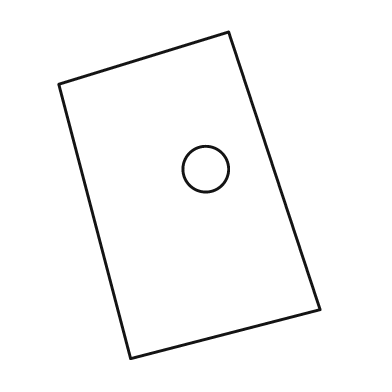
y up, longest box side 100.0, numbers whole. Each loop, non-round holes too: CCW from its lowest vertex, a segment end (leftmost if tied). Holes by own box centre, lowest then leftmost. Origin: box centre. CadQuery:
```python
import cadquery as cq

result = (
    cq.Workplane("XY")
    .moveTo(-18.0, -50.0)
    .lineTo(40.0, -35.0)
    .lineTo(12.0, 50.0)
    .lineTo(-40.0, 34.0)
    .close()
    .moveTo(5.0, 8.0)
    .circle(7.0)
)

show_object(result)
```